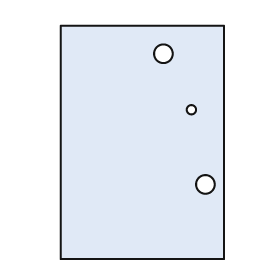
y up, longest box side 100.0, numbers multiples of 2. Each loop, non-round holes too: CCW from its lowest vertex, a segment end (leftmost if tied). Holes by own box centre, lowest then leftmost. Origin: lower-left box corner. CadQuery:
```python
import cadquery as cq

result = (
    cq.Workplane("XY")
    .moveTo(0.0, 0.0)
    .lineTo(70.0, 0.0)
    .lineTo(70.0, 100.0)
    .lineTo(0.0, 100.0)
    .close()
    .moveTo(62.0, 32.0)
    .circle(4.0)
    .moveTo(56.0, 64.0)
    .circle(2.0)
    .moveTo(44.0, 88.0)
    .circle(4.0)
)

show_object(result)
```